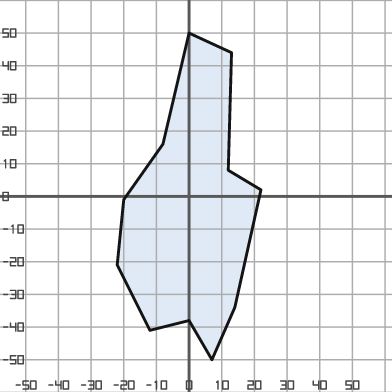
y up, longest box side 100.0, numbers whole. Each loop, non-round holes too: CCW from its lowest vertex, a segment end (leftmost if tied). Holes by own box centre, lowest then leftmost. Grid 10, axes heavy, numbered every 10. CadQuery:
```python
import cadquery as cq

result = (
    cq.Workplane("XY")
    .moveTo(7.0, -50.0)
    .lineTo(14.0, -34.0)
    .lineTo(22.0, 2.0)
    .lineTo(12.0, 8.0)
    .lineTo(13.0, 44.0)
    .lineTo(0.0, 50.0)
    .lineTo(-8.0, 16.0)
    .lineTo(-20.0, -1.0)
    .lineTo(-22.0, -21.0)
    .lineTo(-12.0, -41.0)
    .lineTo(0.0, -38.0)
    .close()
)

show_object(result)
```